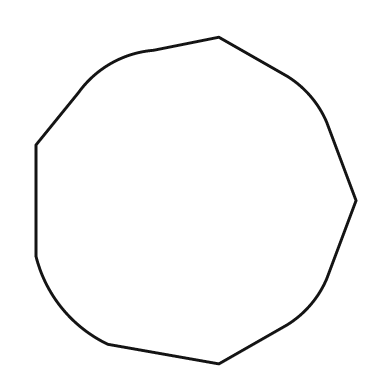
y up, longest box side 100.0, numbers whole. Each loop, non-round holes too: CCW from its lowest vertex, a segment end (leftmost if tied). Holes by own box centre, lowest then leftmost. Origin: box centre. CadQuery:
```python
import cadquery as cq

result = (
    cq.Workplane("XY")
    .moveTo(7.0, -50.0)
    .lineTo(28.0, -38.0)
    .threePointArc((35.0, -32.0), (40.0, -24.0))
    .lineTo(49.0, 0.0)
    .lineTo(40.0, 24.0)
    .threePointArc((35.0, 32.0), (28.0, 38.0))
    .lineTo(7.0, 50.0)
    .lineTo(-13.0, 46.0)
    .threePointArc((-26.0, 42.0), (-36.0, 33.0))
    .lineTo(-49.0, 17.0)
    .lineTo(-49.0, -17.0)
    .threePointArc((-41.0, -33.0), (-27.0, -44.0))
    .close()
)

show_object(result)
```